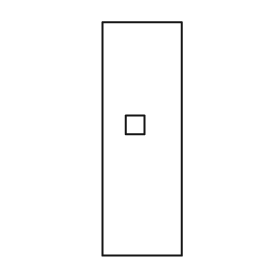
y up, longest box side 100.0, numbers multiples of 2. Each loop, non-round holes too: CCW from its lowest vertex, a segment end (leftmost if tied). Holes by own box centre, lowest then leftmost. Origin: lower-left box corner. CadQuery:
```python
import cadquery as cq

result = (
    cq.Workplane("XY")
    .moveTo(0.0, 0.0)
    .lineTo(34.0, 0.0)
    .lineTo(34.0, 100.0)
    .lineTo(0.0, 100.0)
    .close()
    .moveTo(10.0, 52.0)
    .lineTo(18.0, 52.0)
    .lineTo(18.0, 60.0)
    .lineTo(10.0, 60.0)
    .close()
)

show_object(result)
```